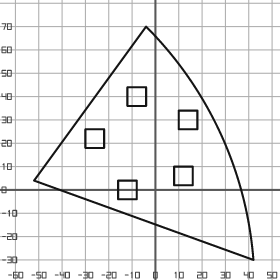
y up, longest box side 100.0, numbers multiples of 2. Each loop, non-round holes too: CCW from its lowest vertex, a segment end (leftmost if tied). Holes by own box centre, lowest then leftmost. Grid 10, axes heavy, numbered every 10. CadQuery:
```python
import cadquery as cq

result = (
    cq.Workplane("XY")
    .moveTo(42.0, -30.0)
    .threePointArc((28.0, 24.0), (-4.0, 70.0))
    .lineTo(-52.0, 4.0)
    .close()
    .moveTo(-16.0, -4.0)
    .lineTo(-8.0, -4.0)
    .lineTo(-8.0, 4.0)
    .lineTo(-16.0, 4.0)
    .close()
    .moveTo(8.0, 2.0)
    .lineTo(16.0, 2.0)
    .lineTo(16.0, 10.0)
    .lineTo(8.0, 10.0)
    .close()
    .moveTo(-30.0, 18.0)
    .lineTo(-22.0, 18.0)
    .lineTo(-22.0, 26.0)
    .lineTo(-30.0, 26.0)
    .close()
    .moveTo(10.0, 26.0)
    .lineTo(18.0, 26.0)
    .lineTo(18.0, 34.0)
    .lineTo(10.0, 34.0)
    .close()
    .moveTo(-12.0, 36.0)
    .lineTo(-4.0, 36.0)
    .lineTo(-4.0, 44.0)
    .lineTo(-12.0, 44.0)
    .close()
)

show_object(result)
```